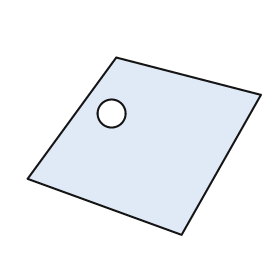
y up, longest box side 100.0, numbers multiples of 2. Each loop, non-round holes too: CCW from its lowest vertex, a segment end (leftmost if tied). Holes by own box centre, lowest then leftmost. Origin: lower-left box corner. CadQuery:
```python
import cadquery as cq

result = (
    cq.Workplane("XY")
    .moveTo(66.0, 0.0)
    .lineTo(100.0, 60.0)
    .lineTo(38.0, 76.0)
    .lineTo(0.0, 24.0)
    .close()
    .moveTo(36.0, 52.0)
    .circle(6.0)
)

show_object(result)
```